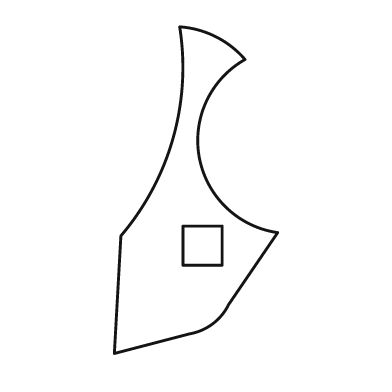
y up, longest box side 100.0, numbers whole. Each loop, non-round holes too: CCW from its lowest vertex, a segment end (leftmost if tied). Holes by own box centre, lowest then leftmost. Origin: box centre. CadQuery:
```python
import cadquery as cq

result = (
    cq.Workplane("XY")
    .moveTo(-25.0, -50.0)
    .lineTo(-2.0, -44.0)
    .threePointArc((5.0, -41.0), (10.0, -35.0))
    .lineTo(25.0, -13.0)
    .threePointArc((1.0, 10.0), (15.0, 40.0))
    .threePointArc((6.0, 47.0), (-5.0, 50.0))
    .threePointArc((-7.0, 16.0), (-23.0, -14.0))
    .close()
    .moveTo(-4.0, -23.0)
    .lineTo(8.0, -23.0)
    .lineTo(8.0, -11.0)
    .lineTo(-4.0, -11.0)
    .close()
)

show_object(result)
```